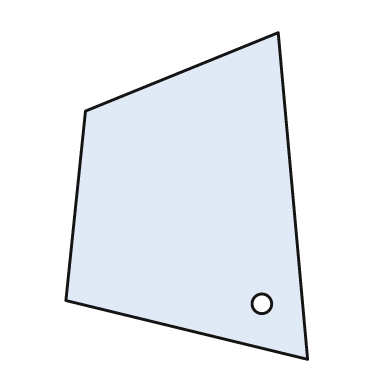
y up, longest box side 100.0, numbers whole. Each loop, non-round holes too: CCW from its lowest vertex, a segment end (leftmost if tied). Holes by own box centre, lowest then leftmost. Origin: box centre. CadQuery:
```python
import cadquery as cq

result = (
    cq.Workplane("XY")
    .moveTo(37.0, -50.0)
    .lineTo(28.0, 50.0)
    .lineTo(-31.0, 26.0)
    .lineTo(-37.0, -32.0)
    .close()
    .moveTo(23.0, -33.0)
    .circle(3.0)
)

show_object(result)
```